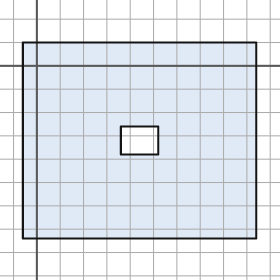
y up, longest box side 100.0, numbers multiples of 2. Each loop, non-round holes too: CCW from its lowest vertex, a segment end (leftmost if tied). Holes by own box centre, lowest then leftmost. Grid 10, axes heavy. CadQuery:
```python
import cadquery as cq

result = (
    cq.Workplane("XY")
    .moveTo(-6.0, -74.0)
    .lineTo(94.0, -74.0)
    .lineTo(94.0, 10.0)
    .lineTo(-6.0, 10.0)
    .close()
    .moveTo(36.0, -38.0)
    .lineTo(52.0, -38.0)
    .lineTo(52.0, -26.0)
    .lineTo(36.0, -26.0)
    .close()
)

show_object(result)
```